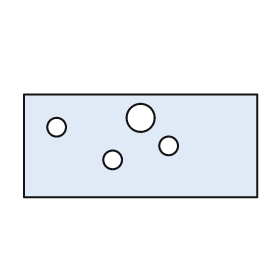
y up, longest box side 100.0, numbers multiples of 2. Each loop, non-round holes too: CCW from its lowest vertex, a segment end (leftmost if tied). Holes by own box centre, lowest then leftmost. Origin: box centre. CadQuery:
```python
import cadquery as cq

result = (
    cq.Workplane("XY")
    .moveTo(-50.0, -22.0)
    .lineTo(50.0, -22.0)
    .lineTo(50.0, 22.0)
    .lineTo(-50.0, 22.0)
    .close()
    .moveTo(-12.0, -6.0)
    .circle(4.0)
    .moveTo(12.0, 0.0)
    .circle(4.0)
    .moveTo(-36.0, 8.0)
    .circle(4.0)
    .moveTo(0.0, 12.0)
    .circle(6.0)
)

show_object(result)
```